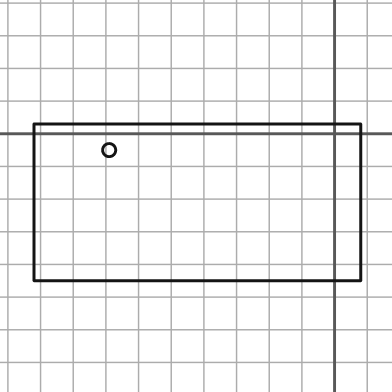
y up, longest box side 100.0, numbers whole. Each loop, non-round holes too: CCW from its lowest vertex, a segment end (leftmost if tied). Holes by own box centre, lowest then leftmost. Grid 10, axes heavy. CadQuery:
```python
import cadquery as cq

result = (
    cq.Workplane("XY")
    .moveTo(-92.0, -45.0)
    .lineTo(8.0, -45.0)
    .lineTo(8.0, 3.0)
    .lineTo(-92.0, 3.0)
    .close()
    .moveTo(-69.0, -5.0)
    .circle(2.0)
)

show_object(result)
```